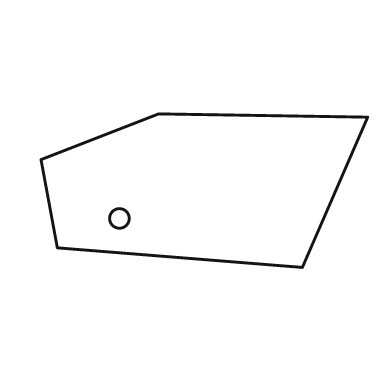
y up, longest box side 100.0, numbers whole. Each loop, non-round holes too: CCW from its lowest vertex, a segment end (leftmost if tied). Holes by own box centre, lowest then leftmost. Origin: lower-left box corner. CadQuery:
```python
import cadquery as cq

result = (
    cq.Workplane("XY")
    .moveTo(80.0, 0.0)
    .lineTo(100.0, 46.0)
    .lineTo(36.0, 47.0)
    .lineTo(0.0, 33.0)
    .lineTo(5.0, 6.0)
    .close()
    .moveTo(24.0, 15.0)
    .circle(3.0)
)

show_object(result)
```